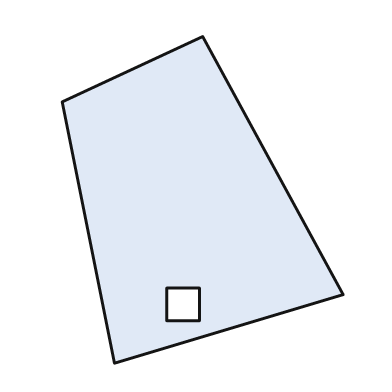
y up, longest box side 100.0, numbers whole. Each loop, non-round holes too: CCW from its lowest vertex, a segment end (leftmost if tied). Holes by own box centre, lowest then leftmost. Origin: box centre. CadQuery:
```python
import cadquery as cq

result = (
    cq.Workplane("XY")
    .moveTo(-27.0, -50.0)
    .lineTo(43.0, -29.0)
    .lineTo(0.0, 50.0)
    .lineTo(-43.0, 30.0)
    .close()
    .moveTo(-11.0, -37.0)
    .lineTo(-1.0, -37.0)
    .lineTo(-1.0, -27.0)
    .lineTo(-11.0, -27.0)
    .close()
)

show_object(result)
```